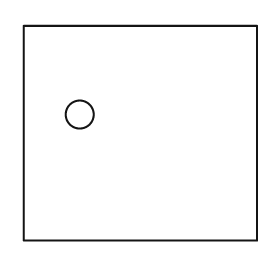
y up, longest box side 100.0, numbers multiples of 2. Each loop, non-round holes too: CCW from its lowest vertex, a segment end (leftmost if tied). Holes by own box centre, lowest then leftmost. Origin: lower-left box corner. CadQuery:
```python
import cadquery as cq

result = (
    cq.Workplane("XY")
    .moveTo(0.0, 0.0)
    .lineTo(100.0, 0.0)
    .lineTo(100.0, 92.0)
    .lineTo(0.0, 92.0)
    .close()
    .moveTo(24.0, 54.0)
    .circle(6.0)
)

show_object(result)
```